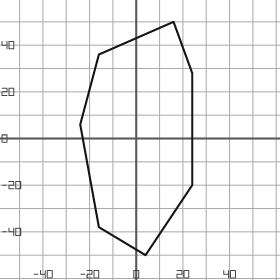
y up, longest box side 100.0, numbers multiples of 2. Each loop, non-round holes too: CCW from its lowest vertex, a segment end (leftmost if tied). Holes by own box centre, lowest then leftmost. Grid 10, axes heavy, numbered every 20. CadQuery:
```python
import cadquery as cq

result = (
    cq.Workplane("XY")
    .moveTo(4.0, -50.0)
    .lineTo(24.0, -20.0)
    .lineTo(24.0, 28.0)
    .lineTo(16.0, 50.0)
    .lineTo(-16.0, 36.0)
    .lineTo(-24.0, 6.0)
    .lineTo(-16.0, -38.0)
    .close()
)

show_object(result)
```